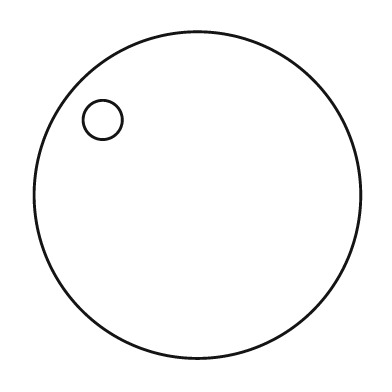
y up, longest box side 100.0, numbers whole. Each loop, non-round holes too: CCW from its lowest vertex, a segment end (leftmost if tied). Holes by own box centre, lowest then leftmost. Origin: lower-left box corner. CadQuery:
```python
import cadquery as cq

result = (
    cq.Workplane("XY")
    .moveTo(50.0, 50.0)
    .circle(50.0)
    .moveTo(21.0, 73.0)
    .circle(6.0)
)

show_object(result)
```